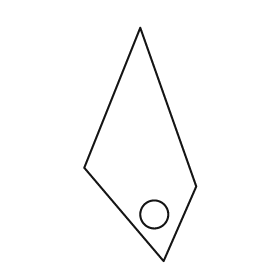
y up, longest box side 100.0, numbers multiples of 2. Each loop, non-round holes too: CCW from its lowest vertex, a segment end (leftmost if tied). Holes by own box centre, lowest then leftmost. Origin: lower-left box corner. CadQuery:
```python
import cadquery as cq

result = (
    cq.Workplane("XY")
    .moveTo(34.0, 0.0)
    .lineTo(48.0, 32.0)
    .lineTo(24.0, 100.0)
    .lineTo(0.0, 40.0)
    .close()
    .moveTo(30.0, 20.0)
    .circle(6.0)
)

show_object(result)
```